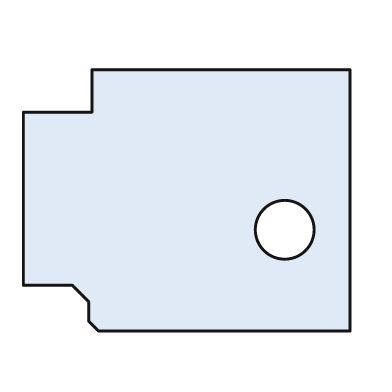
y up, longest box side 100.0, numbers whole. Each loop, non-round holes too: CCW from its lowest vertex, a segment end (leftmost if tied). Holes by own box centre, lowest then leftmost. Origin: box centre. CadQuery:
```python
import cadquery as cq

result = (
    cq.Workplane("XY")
    .moveTo(-27.0, -40.0)
    .lineTo(50.0, -40.0)
    .lineTo(50.0, 40.0)
    .lineTo(-29.0, 40.0)
    .lineTo(-29.0, 27.0)
    .lineTo(-50.0, 27.0)
    .lineTo(-50.0, -26.0)
    .lineTo(-35.0, -26.0)
    .lineTo(-30.0, -31.0)
    .lineTo(-30.0, -37.0)
    .close()
    .moveTo(30.0, -9.0)
    .circle(9.0)
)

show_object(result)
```